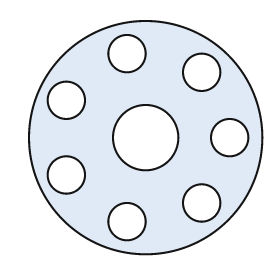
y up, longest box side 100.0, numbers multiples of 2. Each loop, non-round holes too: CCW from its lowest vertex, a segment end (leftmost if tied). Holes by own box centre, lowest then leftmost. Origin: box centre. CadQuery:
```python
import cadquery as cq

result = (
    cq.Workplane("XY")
    .moveTo(0.0, 0.0)
    .circle(50.0)
    .moveTo(-8.0, -36.0)
    .circle(8.0)
    .moveTo(24.0, -28.0)
    .circle(8.0)
    .moveTo(-34.0, -16.0)
    .circle(8.0)
    .moveTo(0.0, 0.0)
    .circle(14.0)
    .moveTo(36.0, 0.0)
    .circle(8.0)
    .moveTo(-34.0, 16.0)
    .circle(8.0)
    .moveTo(24.0, 28.0)
    .circle(8.0)
    .moveTo(-8.0, 36.0)
    .circle(8.0)
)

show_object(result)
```